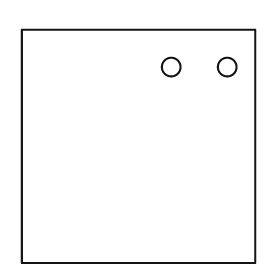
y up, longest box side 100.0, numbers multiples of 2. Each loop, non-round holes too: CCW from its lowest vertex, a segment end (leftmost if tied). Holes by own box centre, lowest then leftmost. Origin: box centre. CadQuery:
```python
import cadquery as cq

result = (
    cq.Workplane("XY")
    .moveTo(-50.0, -50.0)
    .lineTo(50.0, -50.0)
    .lineTo(50.0, 50.0)
    .lineTo(-50.0, 50.0)
    .close()
    .moveTo(14.0, 34.0)
    .circle(4.0)
    .moveTo(38.0, 34.0)
    .circle(4.0)
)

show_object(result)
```